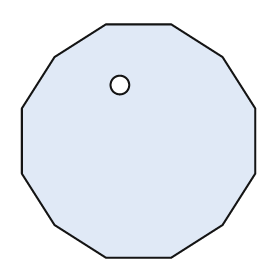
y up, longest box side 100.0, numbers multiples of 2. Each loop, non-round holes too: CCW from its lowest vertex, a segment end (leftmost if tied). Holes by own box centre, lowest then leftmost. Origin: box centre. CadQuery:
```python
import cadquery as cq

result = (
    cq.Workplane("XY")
    .moveTo(-14.0, -50.0)
    .lineTo(14.0, -50.0)
    .lineTo(36.0, -36.0)
    .lineTo(50.0, -14.0)
    .lineTo(50.0, 14.0)
    .lineTo(36.0, 36.0)
    .lineTo(14.0, 50.0)
    .lineTo(-14.0, 50.0)
    .lineTo(-36.0, 36.0)
    .lineTo(-50.0, 14.0)
    .lineTo(-50.0, -14.0)
    .lineTo(-36.0, -36.0)
    .close()
    .moveTo(-8.0, 24.0)
    .circle(4.0)
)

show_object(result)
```